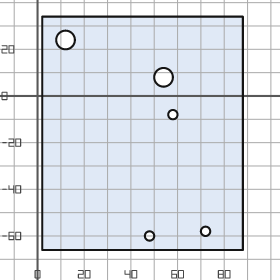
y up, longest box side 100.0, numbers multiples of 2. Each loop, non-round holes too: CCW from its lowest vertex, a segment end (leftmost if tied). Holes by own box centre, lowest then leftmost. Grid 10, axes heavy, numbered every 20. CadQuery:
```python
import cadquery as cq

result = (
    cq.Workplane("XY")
    .moveTo(2.0, -66.0)
    .lineTo(88.0, -66.0)
    .lineTo(88.0, 34.0)
    .lineTo(2.0, 34.0)
    .close()
    .moveTo(48.0, -60.0)
    .circle(2.0)
    .moveTo(72.0, -58.0)
    .circle(2.0)
    .moveTo(58.0, -8.0)
    .circle(2.0)
    .moveTo(54.0, 8.0)
    .circle(4.0)
    .moveTo(12.0, 24.0)
    .circle(4.0)
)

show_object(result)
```